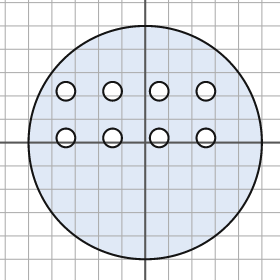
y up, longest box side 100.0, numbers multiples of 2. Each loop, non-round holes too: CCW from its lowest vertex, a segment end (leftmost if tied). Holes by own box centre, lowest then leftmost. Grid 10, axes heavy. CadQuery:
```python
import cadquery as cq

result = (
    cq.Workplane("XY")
    .moveTo(0.0, 0.0)
    .circle(50.0)
    .moveTo(-34.0, 2.0)
    .circle(4.0)
    .moveTo(-14.0, 2.0)
    .circle(4.0)
    .moveTo(6.0, 2.0)
    .circle(4.0)
    .moveTo(26.0, 2.0)
    .circle(4.0)
    .moveTo(-34.0, 22.0)
    .circle(4.0)
    .moveTo(-14.0, 22.0)
    .circle(4.0)
    .moveTo(6.0, 22.0)
    .circle(4.0)
    .moveTo(26.0, 22.0)
    .circle(4.0)
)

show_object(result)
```